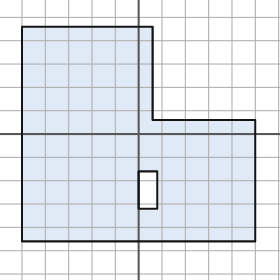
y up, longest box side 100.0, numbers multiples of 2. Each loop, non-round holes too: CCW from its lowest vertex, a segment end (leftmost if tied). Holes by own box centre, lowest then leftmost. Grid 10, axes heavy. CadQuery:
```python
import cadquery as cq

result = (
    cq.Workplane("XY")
    .moveTo(-50.0, -46.0)
    .lineTo(50.0, -46.0)
    .lineTo(50.0, 6.0)
    .lineTo(6.0, 6.0)
    .lineTo(6.0, 46.0)
    .lineTo(-50.0, 46.0)
    .close()
    .moveTo(0.0, -32.0)
    .lineTo(8.0, -32.0)
    .lineTo(8.0, -16.0)
    .lineTo(0.0, -16.0)
    .close()
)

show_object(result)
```